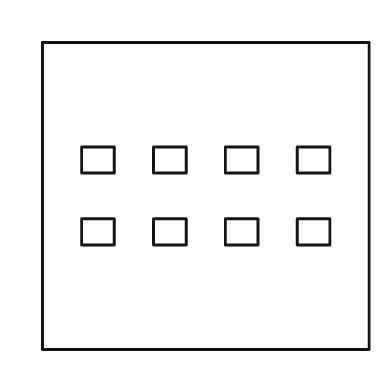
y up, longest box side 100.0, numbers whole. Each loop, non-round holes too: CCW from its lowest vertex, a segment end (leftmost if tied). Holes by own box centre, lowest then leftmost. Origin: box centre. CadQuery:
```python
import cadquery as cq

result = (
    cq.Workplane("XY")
    .moveTo(-50.0, -47.0)
    .lineTo(50.0, -47.0)
    .lineTo(50.0, 47.0)
    .lineTo(-50.0, 47.0)
    .close()
    .moveTo(-38.0, -15.0)
    .lineTo(-28.0, -15.0)
    .lineTo(-28.0, -7.0)
    .lineTo(-38.0, -7.0)
    .close()
    .moveTo(-16.0, -15.0)
    .lineTo(-6.0, -15.0)
    .lineTo(-6.0, -7.0)
    .lineTo(-16.0, -7.0)
    .close()
    .moveTo(6.0, -15.0)
    .lineTo(16.0, -15.0)
    .lineTo(16.0, -7.0)
    .lineTo(6.0, -7.0)
    .close()
    .moveTo(28.0, -15.0)
    .lineTo(38.0, -15.0)
    .lineTo(38.0, -7.0)
    .lineTo(28.0, -7.0)
    .close()
    .moveTo(-38.0, 7.0)
    .lineTo(-28.0, 7.0)
    .lineTo(-28.0, 15.0)
    .lineTo(-38.0, 15.0)
    .close()
    .moveTo(-16.0, 7.0)
    .lineTo(-6.0, 7.0)
    .lineTo(-6.0, 15.0)
    .lineTo(-16.0, 15.0)
    .close()
    .moveTo(6.0, 7.0)
    .lineTo(16.0, 7.0)
    .lineTo(16.0, 15.0)
    .lineTo(6.0, 15.0)
    .close()
    .moveTo(28.0, 7.0)
    .lineTo(38.0, 7.0)
    .lineTo(38.0, 15.0)
    .lineTo(28.0, 15.0)
    .close()
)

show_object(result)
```